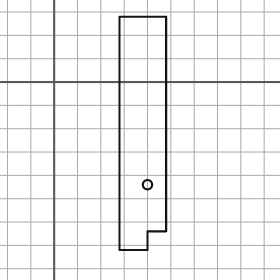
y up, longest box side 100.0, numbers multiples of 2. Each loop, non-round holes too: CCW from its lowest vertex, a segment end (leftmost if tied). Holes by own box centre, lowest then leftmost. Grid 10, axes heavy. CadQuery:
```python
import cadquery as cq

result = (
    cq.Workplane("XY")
    .moveTo(28.0, -72.0)
    .lineTo(40.0, -72.0)
    .lineTo(40.0, -64.0)
    .lineTo(48.0, -64.0)
    .lineTo(48.0, 28.0)
    .lineTo(28.0, 28.0)
    .close()
    .moveTo(40.0, -44.0)
    .circle(2.0)
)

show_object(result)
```